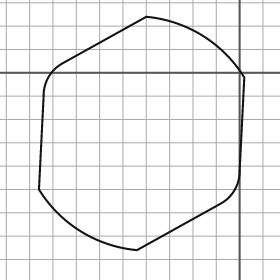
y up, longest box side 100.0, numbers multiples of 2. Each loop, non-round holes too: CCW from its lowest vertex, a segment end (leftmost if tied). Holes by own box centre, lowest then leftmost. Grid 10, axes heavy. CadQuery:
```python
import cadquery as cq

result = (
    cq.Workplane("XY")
    .moveTo(-44.0, -76.0)
    .lineTo(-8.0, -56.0)
    .threePointArc((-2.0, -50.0), (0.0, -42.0))
    .lineTo(2.0, -2.0)
    .threePointArc((-16.0, 16.0), (-40.0, 24.0))
    .lineTo(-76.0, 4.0)
    .threePointArc((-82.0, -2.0), (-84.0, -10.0))
    .lineTo(-86.0, -50.0)
    .threePointArc((-68.0, -68.0), (-44.0, -76.0))
    .close()
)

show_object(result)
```